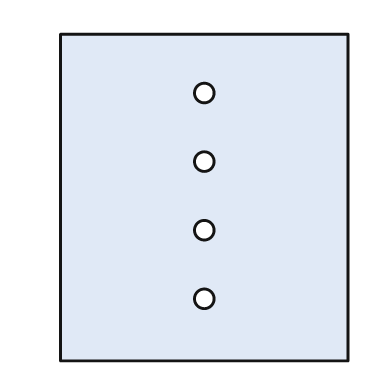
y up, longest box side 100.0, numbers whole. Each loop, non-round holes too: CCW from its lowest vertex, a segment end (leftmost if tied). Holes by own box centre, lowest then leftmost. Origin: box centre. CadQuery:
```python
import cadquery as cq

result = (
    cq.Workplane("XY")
    .moveTo(-44.0, -50.0)
    .lineTo(44.0, -50.0)
    .lineTo(44.0, 50.0)
    .lineTo(-44.0, 50.0)
    .close()
    .moveTo(0.0, -31.0)
    .circle(3.0)
    .moveTo(0.0, -10.0)
    .circle(3.0)
    .moveTo(0.0, 11.0)
    .circle(3.0)
    .moveTo(0.0, 32.0)
    .circle(3.0)
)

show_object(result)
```